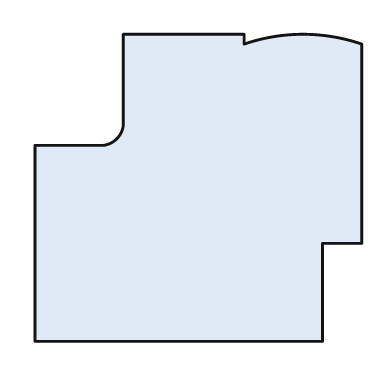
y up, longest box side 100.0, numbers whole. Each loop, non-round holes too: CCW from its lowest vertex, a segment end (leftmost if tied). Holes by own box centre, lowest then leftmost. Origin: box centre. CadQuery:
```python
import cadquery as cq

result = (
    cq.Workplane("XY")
    .moveTo(-50.0, -47.0)
    .lineTo(38.0, -47.0)
    .lineTo(38.0, -17.0)
    .lineTo(50.0, -17.0)
    .lineTo(50.0, 44.0)
    .threePointArc((32.0, 47.0), (14.0, 44.0))
    .lineTo(14.0, 47.0)
    .lineTo(-23.0, 47.0)
    .lineTo(-23.0, 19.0)
    .threePointArc((-25.0, 15.0), (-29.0, 13.0))
    .lineTo(-50.0, 13.0)
    .close()
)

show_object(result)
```